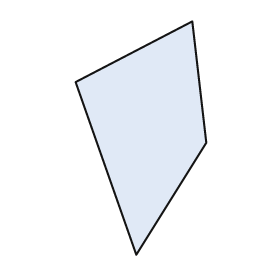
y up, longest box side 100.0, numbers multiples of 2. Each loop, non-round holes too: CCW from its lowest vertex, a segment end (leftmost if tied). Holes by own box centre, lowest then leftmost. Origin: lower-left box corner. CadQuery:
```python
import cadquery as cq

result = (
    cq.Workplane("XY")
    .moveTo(26.0, 0.0)
    .lineTo(56.0, 48.0)
    .lineTo(50.0, 100.0)
    .lineTo(0.0, 74.0)
    .close()
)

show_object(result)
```